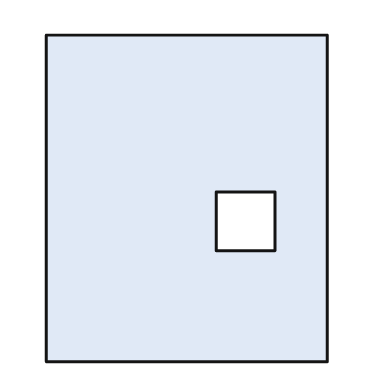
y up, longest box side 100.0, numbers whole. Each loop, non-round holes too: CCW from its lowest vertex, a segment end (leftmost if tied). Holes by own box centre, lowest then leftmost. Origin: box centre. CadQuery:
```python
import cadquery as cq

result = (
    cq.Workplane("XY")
    .moveTo(-43.0, -50.0)
    .lineTo(43.0, -50.0)
    .lineTo(43.0, 50.0)
    .lineTo(-43.0, 50.0)
    .close()
    .moveTo(9.0, -16.0)
    .lineTo(27.0, -16.0)
    .lineTo(27.0, 2.0)
    .lineTo(9.0, 2.0)
    .close()
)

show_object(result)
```